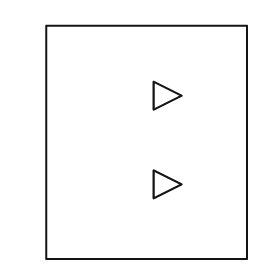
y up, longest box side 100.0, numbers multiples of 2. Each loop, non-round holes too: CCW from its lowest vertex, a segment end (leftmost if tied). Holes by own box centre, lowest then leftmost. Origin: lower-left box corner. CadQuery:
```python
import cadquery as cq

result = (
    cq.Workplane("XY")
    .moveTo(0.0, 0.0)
    .lineTo(86.0, 0.0)
    .lineTo(86.0, 100.0)
    .lineTo(0.0, 100.0)
    .close()
    .moveTo(46.0, 26.0)
    .lineTo(58.0, 32.0)
    .lineTo(46.0, 38.0)
    .close()
    .moveTo(46.0, 64.0)
    .lineTo(58.0, 70.0)
    .lineTo(46.0, 76.0)
    .close()
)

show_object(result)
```